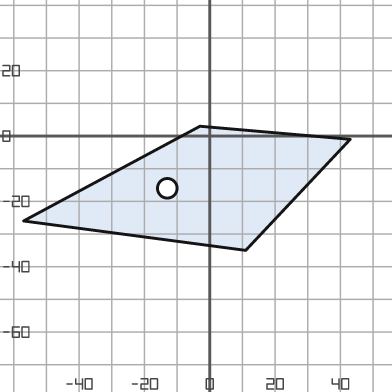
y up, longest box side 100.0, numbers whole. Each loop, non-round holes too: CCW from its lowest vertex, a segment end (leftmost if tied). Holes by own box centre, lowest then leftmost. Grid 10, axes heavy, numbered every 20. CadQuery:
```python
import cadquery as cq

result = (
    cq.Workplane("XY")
    .moveTo(11.0, -35.0)
    .lineTo(43.0, -1.0)
    .lineTo(-3.0, 3.0)
    .lineTo(-57.0, -26.0)
    .close()
    .moveTo(-13.0, -16.0)
    .circle(3.0)
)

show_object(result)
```